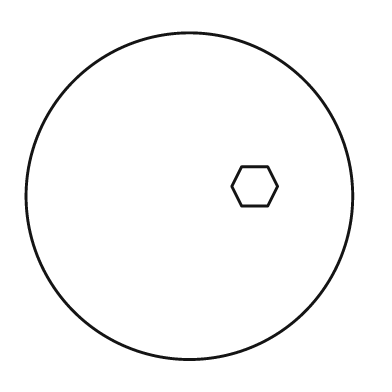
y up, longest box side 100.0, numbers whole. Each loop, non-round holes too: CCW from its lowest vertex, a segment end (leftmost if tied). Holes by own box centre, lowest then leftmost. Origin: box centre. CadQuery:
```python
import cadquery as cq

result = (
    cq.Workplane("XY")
    .moveTo(0.0, 0.0)
    .circle(50.0)
    .moveTo(16.0, -3.0)
    .lineTo(24.0, -3.0)
    .lineTo(27.0, 3.0)
    .lineTo(24.0, 9.0)
    .lineTo(16.0, 9.0)
    .lineTo(13.0, 3.0)
    .close()
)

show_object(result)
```